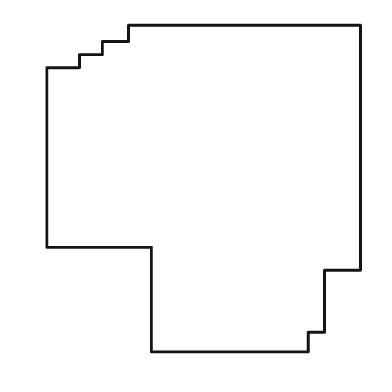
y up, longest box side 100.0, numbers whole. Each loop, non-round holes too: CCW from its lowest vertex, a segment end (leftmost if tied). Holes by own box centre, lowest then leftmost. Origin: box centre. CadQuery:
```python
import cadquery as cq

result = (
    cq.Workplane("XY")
    .moveTo(-16.0, -50.0)
    .lineTo(32.0, -50.0)
    .lineTo(32.0, -44.0)
    .lineTo(37.0, -44.0)
    .lineTo(37.0, -25.0)
    .lineTo(48.0, -25.0)
    .lineTo(48.0, 50.0)
    .lineTo(-23.0, 50.0)
    .lineTo(-23.0, 45.0)
    .lineTo(-31.0, 45.0)
    .lineTo(-31.0, 41.0)
    .lineTo(-38.0, 41.0)
    .lineTo(-38.0, 37.0)
    .lineTo(-48.0, 37.0)
    .lineTo(-48.0, -18.0)
    .lineTo(-16.0, -18.0)
    .close()
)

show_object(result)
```